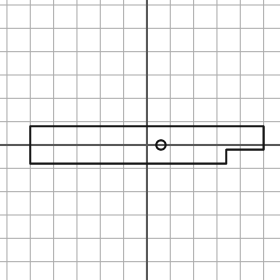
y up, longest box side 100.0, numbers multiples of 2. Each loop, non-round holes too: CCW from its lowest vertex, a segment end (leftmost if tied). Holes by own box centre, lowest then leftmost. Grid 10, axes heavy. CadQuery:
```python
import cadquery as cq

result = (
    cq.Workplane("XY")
    .moveTo(-50.0, -8.0)
    .lineTo(34.0, -8.0)
    .lineTo(34.0, -2.0)
    .lineTo(50.0, -2.0)
    .lineTo(50.0, 8.0)
    .lineTo(-50.0, 8.0)
    .close()
    .moveTo(6.0, 0.0)
    .circle(2.0)
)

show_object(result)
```